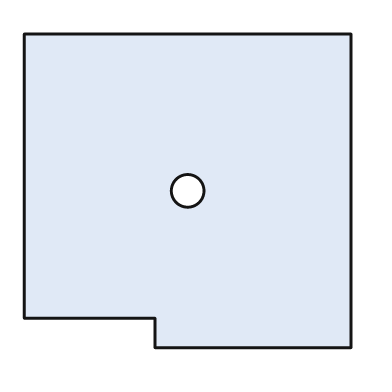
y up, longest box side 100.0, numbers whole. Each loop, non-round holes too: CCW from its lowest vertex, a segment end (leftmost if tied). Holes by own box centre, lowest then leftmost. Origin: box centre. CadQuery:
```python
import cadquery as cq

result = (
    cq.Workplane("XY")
    .moveTo(-10.0, -48.0)
    .lineTo(50.0, -48.0)
    .lineTo(50.0, 48.0)
    .lineTo(-50.0, 48.0)
    .lineTo(-50.0, -39.0)
    .lineTo(-10.0, -39.0)
    .close()
    .moveTo(0.0, 0.0)
    .circle(5.0)
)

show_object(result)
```